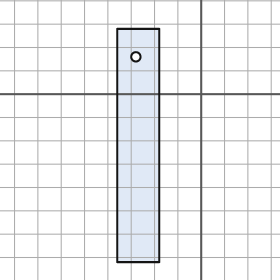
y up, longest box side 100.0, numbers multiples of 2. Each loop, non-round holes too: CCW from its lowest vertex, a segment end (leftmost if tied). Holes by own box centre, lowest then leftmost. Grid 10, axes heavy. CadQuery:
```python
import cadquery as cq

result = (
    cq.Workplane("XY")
    .moveTo(-36.0, -72.0)
    .lineTo(-18.0, -72.0)
    .lineTo(-18.0, 28.0)
    .lineTo(-36.0, 28.0)
    .close()
    .moveTo(-28.0, 16.0)
    .circle(2.0)
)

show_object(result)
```